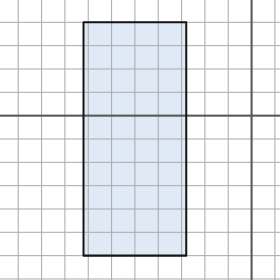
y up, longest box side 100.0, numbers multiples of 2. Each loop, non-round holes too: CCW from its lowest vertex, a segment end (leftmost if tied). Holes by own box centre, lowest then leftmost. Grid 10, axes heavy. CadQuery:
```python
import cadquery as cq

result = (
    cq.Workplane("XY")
    .moveTo(-72.0, -60.0)
    .lineTo(-28.0, -60.0)
    .lineTo(-28.0, 40.0)
    .lineTo(-72.0, 40.0)
    .close()
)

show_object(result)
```